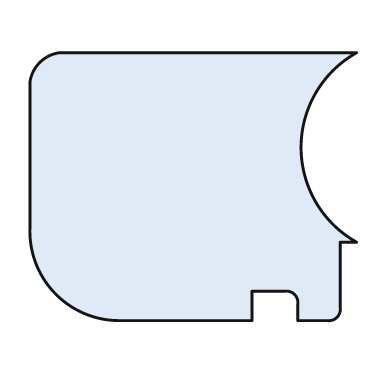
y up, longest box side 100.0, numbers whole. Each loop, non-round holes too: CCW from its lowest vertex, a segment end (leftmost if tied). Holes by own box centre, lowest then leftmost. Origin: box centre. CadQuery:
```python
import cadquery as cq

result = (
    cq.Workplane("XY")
    .moveTo(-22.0, -41.0)
    .lineTo(18.0, -41.0)
    .lineTo(18.0, -32.0)
    .lineTo(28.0, -32.0)
    .threePointArc((31.0, -33.0), (32.0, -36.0))
    .lineTo(32.0, -41.0)
    .lineTo(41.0, -41.0)
    .threePointArc((44.0, -40.0), (45.0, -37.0))
    .lineTo(45.0, -17.0)
    .lineTo(50.0, -17.0)
    .threePointArc((33.0, 12.0), (50.0, 41.0))
    .lineTo(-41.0, 41.0)
    .threePointArc((-47.0, 38.0), (-50.0, 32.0))
    .lineTo(-50.0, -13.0)
    .threePointArc((-42.0, -33.0), (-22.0, -41.0))
    .close()
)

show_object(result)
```